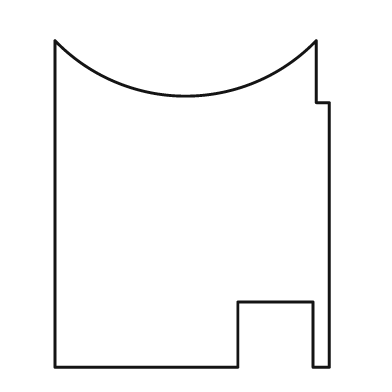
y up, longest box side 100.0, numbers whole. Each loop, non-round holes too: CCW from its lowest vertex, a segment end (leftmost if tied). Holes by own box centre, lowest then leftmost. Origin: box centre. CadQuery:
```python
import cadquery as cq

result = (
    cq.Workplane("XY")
    .moveTo(-42.0, -50.0)
    .lineTo(14.0, -50.0)
    .lineTo(14.0, -30.0)
    .lineTo(37.0, -30.0)
    .lineTo(37.0, -50.0)
    .lineTo(42.0, -50.0)
    .lineTo(42.0, 31.0)
    .lineTo(38.0, 31.0)
    .lineTo(38.0, 50.0)
    .threePointArc((-2.0, 33.0), (-42.0, 50.0))
    .close()
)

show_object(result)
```